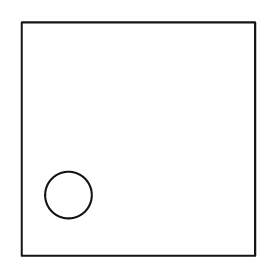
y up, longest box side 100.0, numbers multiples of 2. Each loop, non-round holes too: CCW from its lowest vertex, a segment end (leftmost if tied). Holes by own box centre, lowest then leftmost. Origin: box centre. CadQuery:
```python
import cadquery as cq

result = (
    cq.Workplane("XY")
    .moveTo(-50.0, -50.0)
    .lineTo(50.0, -50.0)
    .lineTo(50.0, 50.0)
    .lineTo(-50.0, 50.0)
    .close()
    .moveTo(-30.0, -24.0)
    .circle(10.0)
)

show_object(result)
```